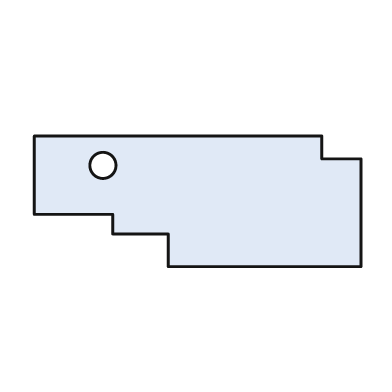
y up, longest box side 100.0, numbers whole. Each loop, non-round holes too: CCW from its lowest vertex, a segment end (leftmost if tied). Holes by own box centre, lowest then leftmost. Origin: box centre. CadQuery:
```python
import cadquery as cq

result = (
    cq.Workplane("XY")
    .moveTo(-9.0, -20.0)
    .lineTo(50.0, -20.0)
    .lineTo(50.0, 13.0)
    .lineTo(38.0, 13.0)
    .lineTo(38.0, 20.0)
    .lineTo(-50.0, 20.0)
    .lineTo(-50.0, -4.0)
    .lineTo(-26.0, -4.0)
    .lineTo(-26.0, -10.0)
    .lineTo(-9.0, -10.0)
    .close()
    .moveTo(-29.0, 11.0)
    .circle(4.0)
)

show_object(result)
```